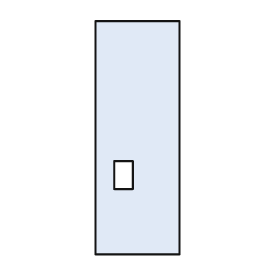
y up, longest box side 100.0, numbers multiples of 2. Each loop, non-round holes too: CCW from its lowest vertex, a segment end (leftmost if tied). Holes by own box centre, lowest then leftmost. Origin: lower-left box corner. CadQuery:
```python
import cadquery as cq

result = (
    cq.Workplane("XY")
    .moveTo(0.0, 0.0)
    .lineTo(36.0, 0.0)
    .lineTo(36.0, 100.0)
    .lineTo(0.0, 100.0)
    .close()
    .moveTo(8.0, 28.0)
    .lineTo(16.0, 28.0)
    .lineTo(16.0, 40.0)
    .lineTo(8.0, 40.0)
    .close()
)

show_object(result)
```